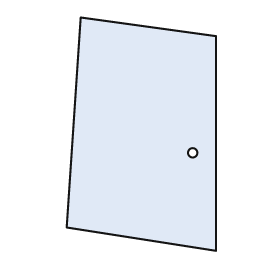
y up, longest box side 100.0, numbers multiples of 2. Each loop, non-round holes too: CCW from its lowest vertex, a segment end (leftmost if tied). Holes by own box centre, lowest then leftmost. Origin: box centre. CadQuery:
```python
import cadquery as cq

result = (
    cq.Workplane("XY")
    .moveTo(32.0, -50.0)
    .lineTo(32.0, 42.0)
    .lineTo(-26.0, 50.0)
    .lineTo(-32.0, -40.0)
    .close()
    .moveTo(22.0, -8.0)
    .circle(2.0)
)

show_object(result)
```